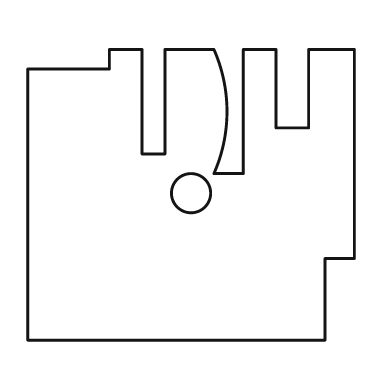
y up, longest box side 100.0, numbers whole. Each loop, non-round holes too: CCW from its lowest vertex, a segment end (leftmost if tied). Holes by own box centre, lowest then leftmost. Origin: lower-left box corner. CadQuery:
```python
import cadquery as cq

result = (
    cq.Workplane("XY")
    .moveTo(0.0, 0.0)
    .lineTo(91.0, 0.0)
    .lineTo(91.0, 25.0)
    .lineTo(100.0, 25.0)
    .lineTo(100.0, 89.0)
    .lineTo(86.0, 89.0)
    .lineTo(86.0, 65.0)
    .lineTo(76.0, 65.0)
    .lineTo(76.0, 89.0)
    .lineTo(66.0, 89.0)
    .lineTo(66.0, 51.0)
    .lineTo(57.0, 51.0)
    .threePointArc((61.0, 70.0), (57.0, 89.0))
    .lineTo(42.0, 89.0)
    .lineTo(42.0, 57.0)
    .lineTo(35.0, 57.0)
    .lineTo(35.0, 89.0)
    .lineTo(25.0, 89.0)
    .lineTo(25.0, 83.0)
    .lineTo(0.0, 83.0)
    .close()
    .moveTo(50.0, 45.0)
    .circle(6.0)
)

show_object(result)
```